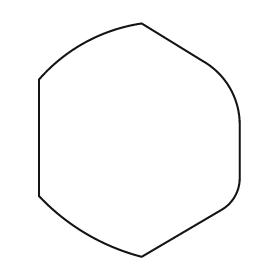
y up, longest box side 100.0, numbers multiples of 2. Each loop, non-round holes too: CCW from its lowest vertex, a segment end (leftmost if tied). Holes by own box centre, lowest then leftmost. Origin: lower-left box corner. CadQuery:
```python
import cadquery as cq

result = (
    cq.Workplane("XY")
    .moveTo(44.0, 0.0)
    .lineTo(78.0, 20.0)
    .threePointArc((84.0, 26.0), (86.0, 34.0))
    .lineTo(86.0, 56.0)
    .threePointArc((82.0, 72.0), (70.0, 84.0))
    .lineTo(44.0, 100.0)
    .threePointArc((20.0, 92.0), (0.0, 76.0))
    .lineTo(0.0, 26.0)
    .threePointArc((20.0, 10.0), (44.0, 0.0))
    .close()
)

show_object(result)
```